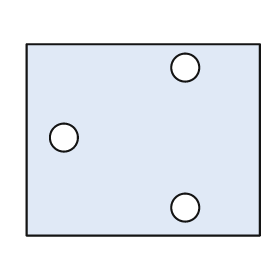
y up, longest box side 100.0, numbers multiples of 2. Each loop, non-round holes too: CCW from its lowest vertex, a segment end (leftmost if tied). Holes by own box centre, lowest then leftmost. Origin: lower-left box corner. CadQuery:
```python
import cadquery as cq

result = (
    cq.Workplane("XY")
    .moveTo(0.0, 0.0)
    .lineTo(100.0, 0.0)
    .lineTo(100.0, 82.0)
    .lineTo(0.0, 82.0)
    .close()
    .moveTo(68.0, 12.0)
    .circle(6.0)
    .moveTo(16.0, 42.0)
    .circle(6.0)
    .moveTo(68.0, 72.0)
    .circle(6.0)
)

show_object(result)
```